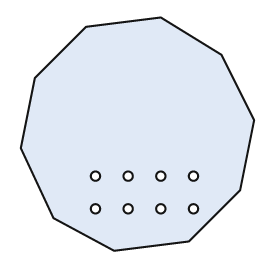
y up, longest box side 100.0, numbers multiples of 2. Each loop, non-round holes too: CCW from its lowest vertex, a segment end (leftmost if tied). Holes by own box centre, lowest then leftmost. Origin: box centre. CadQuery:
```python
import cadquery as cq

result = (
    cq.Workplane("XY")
    .moveTo(-10.0, -50.0)
    .lineTo(22.0, -46.0)
    .lineTo(44.0, -24.0)
    .lineTo(50.0, 6.0)
    .lineTo(36.0, 34.0)
    .lineTo(10.0, 50.0)
    .lineTo(-22.0, 46.0)
    .lineTo(-44.0, 24.0)
    .lineTo(-50.0, -6.0)
    .lineTo(-36.0, -36.0)
    .close()
    .moveTo(-18.0, -32.0)
    .circle(2.0)
    .moveTo(-4.0, -32.0)
    .circle(2.0)
    .moveTo(10.0, -32.0)
    .circle(2.0)
    .moveTo(24.0, -32.0)
    .circle(2.0)
    .moveTo(-18.0, -18.0)
    .circle(2.0)
    .moveTo(-4.0, -18.0)
    .circle(2.0)
    .moveTo(10.0, -18.0)
    .circle(2.0)
    .moveTo(24.0, -18.0)
    .circle(2.0)
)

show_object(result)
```